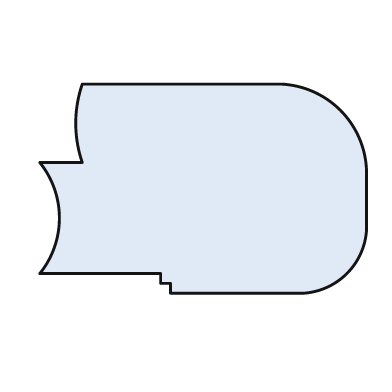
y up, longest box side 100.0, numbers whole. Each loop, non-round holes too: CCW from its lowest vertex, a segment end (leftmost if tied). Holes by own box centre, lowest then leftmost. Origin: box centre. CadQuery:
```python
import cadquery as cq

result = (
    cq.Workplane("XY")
    .moveTo(-10.0, -32.0)
    .lineTo(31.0, -32.0)
    .threePointArc((44.0, -26.0), (50.0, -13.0))
    .lineTo(50.0, 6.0)
    .threePointArc((42.0, 24.0), (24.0, 32.0))
    .lineTo(-37.0, 32.0)
    .threePointArc((-39.0, 20.0), (-37.0, 8.0))
    .lineTo(-50.0, 8.0)
    .threePointArc((-44.0, -9.0), (-50.0, -26.0))
    .lineTo(-13.0, -26.0)
    .lineTo(-13.0, -29.0)
    .lineTo(-10.0, -29.0)
    .close()
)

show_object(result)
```